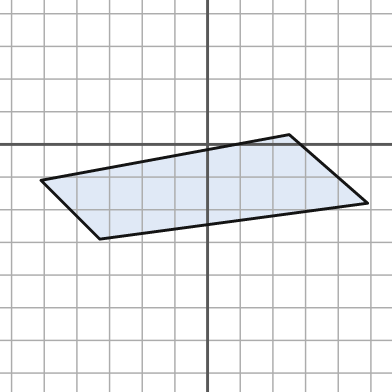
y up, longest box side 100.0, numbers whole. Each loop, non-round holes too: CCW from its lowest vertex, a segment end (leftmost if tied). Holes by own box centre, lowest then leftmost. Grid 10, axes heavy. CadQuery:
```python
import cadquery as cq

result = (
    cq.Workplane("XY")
    .moveTo(-33.0, -29.0)
    .lineTo(49.0, -18.0)
    .lineTo(25.0, 3.0)
    .lineTo(-51.0, -11.0)
    .close()
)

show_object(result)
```